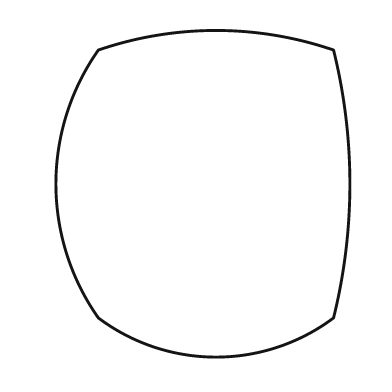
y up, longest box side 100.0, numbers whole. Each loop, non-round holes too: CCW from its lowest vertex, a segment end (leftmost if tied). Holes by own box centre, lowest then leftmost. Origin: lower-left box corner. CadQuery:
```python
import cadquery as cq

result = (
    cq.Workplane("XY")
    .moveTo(13.0, 12.0)
    .threePointArc((49.0, 0.0), (85.0, 12.0))
    .threePointArc((90.0, 53.0), (85.0, 94.0))
    .threePointArc((49.0, 100.0), (13.0, 94.0))
    .threePointArc((0.0, 53.0), (13.0, 12.0))
    .close()
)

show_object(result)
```